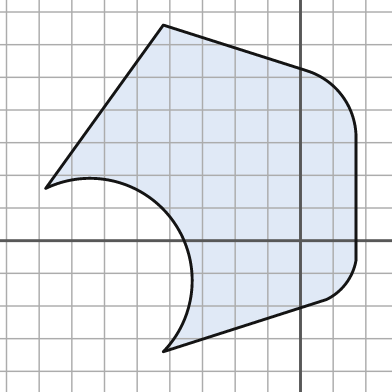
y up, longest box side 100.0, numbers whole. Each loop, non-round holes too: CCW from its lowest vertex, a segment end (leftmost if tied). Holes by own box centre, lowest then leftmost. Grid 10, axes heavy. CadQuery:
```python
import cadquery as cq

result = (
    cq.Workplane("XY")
    .moveTo(-42.0, -34.0)
    .lineTo(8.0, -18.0)
    .threePointArc((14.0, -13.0), (17.0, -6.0))
    .lineTo(17.0, 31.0)
    .threePointArc((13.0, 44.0), (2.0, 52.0))
    .lineTo(-42.0, 66.0)
    .lineTo(-78.0, 16.0)
    .threePointArc((-39.0, 6.0), (-42.0, -34.0))
    .close()
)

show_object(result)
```